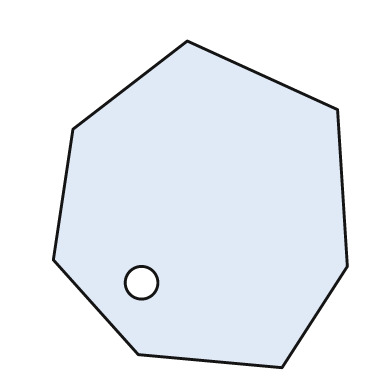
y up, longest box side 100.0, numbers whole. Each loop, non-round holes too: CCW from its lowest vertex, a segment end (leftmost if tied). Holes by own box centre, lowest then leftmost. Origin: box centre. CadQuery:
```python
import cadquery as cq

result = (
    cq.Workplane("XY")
    .moveTo(25.0, -50.0)
    .lineTo(45.0, -19.0)
    .lineTo(42.0, 29.0)
    .lineTo(-4.0, 50.0)
    .lineTo(-39.0, 23.0)
    .lineTo(-45.0, -17.0)
    .lineTo(-19.0, -46.0)
    .close()
    .moveTo(-18.0, -24.0)
    .circle(5.0)
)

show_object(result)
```